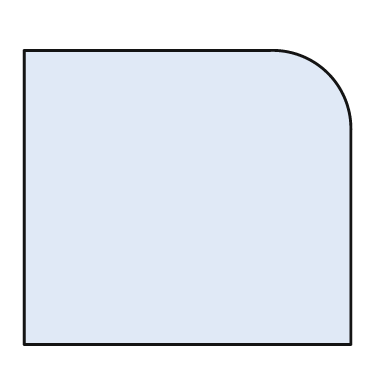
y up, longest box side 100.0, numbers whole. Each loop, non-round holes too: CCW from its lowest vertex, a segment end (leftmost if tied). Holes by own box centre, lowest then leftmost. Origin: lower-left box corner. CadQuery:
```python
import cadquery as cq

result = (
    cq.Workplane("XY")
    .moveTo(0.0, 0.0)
    .lineTo(100.0, 0.0)
    .lineTo(100.0, 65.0)
    .threePointArc((93.0, 83.0), (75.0, 90.0))
    .lineTo(0.0, 90.0)
    .close()
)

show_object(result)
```